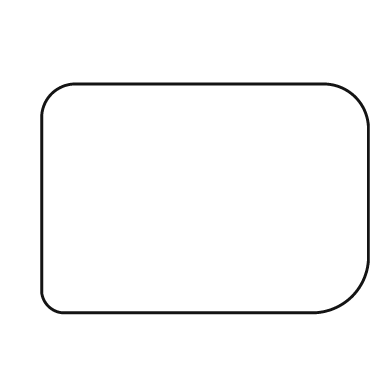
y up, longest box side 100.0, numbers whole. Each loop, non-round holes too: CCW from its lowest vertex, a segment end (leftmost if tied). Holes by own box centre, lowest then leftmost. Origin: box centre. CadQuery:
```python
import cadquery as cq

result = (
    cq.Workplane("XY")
    .moveTo(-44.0, -35.0)
    .lineTo(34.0, -35.0)
    .threePointArc((45.0, -30.0), (50.0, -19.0))
    .lineTo(50.0, 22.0)
    .threePointArc((46.0, 31.0), (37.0, 35.0))
    .lineTo(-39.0, 35.0)
    .threePointArc((-47.0, 32.0), (-50.0, 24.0))
    .lineTo(-50.0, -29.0)
    .threePointArc((-48.0, -33.0), (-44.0, -35.0))
    .close()
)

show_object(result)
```